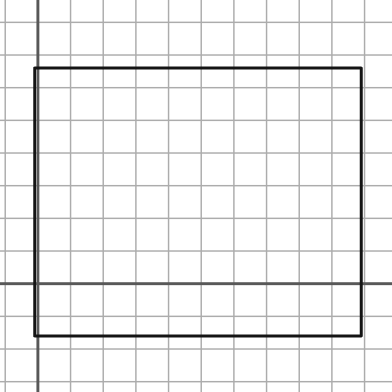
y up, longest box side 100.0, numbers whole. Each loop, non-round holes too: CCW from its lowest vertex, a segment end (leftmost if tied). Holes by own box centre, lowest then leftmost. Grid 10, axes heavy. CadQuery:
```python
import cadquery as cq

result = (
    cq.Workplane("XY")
    .moveTo(-1.0, -16.0)
    .lineTo(99.0, -16.0)
    .lineTo(99.0, 66.0)
    .lineTo(-1.0, 66.0)
    .close()
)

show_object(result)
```